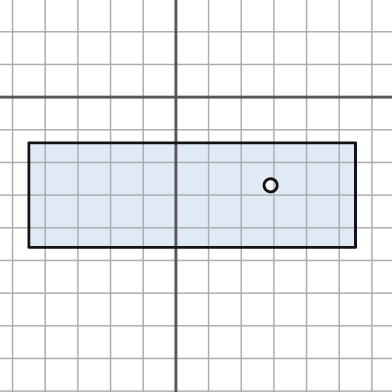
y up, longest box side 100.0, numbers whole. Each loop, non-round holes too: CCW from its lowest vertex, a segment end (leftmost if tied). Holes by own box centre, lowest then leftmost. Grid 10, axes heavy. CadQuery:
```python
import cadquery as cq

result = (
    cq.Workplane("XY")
    .moveTo(-45.0, -46.0)
    .lineTo(55.0, -46.0)
    .lineTo(55.0, -14.0)
    .lineTo(-45.0, -14.0)
    .close()
    .moveTo(29.0, -27.0)
    .circle(2.0)
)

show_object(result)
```